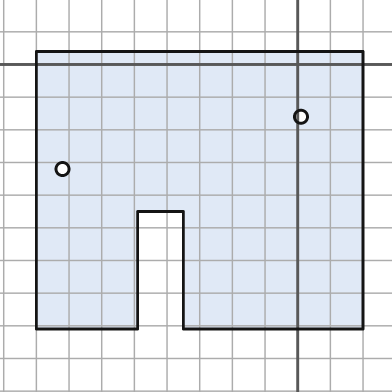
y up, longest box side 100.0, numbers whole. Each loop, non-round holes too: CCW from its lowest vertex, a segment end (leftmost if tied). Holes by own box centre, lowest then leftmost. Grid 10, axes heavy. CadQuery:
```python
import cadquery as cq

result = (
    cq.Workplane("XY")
    .moveTo(-80.0, -81.0)
    .lineTo(-49.0, -81.0)
    .lineTo(-49.0, -45.0)
    .lineTo(-35.0, -45.0)
    .lineTo(-35.0, -81.0)
    .lineTo(20.0, -81.0)
    .lineTo(20.0, 4.0)
    .lineTo(-80.0, 4.0)
    .close()
    .moveTo(-72.0, -32.0)
    .circle(2.0)
    .moveTo(1.0, -16.0)
    .circle(2.0)
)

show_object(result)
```